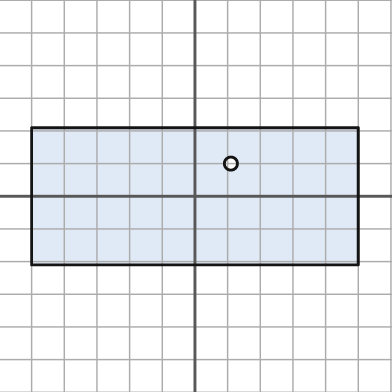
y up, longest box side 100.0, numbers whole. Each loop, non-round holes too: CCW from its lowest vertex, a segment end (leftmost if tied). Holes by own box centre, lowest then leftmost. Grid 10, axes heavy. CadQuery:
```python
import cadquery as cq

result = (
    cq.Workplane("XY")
    .moveTo(-50.0, -21.0)
    .lineTo(50.0, -21.0)
    .lineTo(50.0, 21.0)
    .lineTo(-50.0, 21.0)
    .close()
    .moveTo(11.0, 10.0)
    .circle(2.0)
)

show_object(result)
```